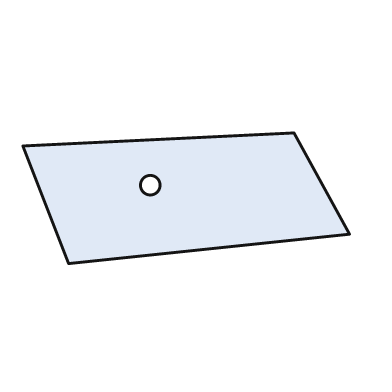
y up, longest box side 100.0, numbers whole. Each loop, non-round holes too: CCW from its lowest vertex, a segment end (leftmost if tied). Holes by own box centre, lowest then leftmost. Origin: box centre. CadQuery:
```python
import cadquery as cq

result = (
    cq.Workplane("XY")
    .moveTo(-36.0, -20.0)
    .lineTo(50.0, -11.0)
    .lineTo(33.0, 20.0)
    .lineTo(-50.0, 16.0)
    .close()
    .moveTo(-11.0, 4.0)
    .circle(3.0)
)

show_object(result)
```